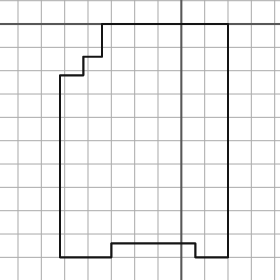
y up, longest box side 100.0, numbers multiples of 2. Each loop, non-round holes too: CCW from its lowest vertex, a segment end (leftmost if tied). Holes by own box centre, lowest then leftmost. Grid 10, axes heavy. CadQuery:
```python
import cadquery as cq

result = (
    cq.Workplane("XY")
    .moveTo(-52.0, -100.0)
    .lineTo(-30.0, -100.0)
    .lineTo(-30.0, -94.0)
    .lineTo(6.0, -94.0)
    .lineTo(6.0, -100.0)
    .lineTo(20.0, -100.0)
    .lineTo(20.0, 0.0)
    .lineTo(-34.0, 0.0)
    .lineTo(-34.0, -14.0)
    .lineTo(-42.0, -14.0)
    .lineTo(-42.0, -22.0)
    .lineTo(-52.0, -22.0)
    .close()
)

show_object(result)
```